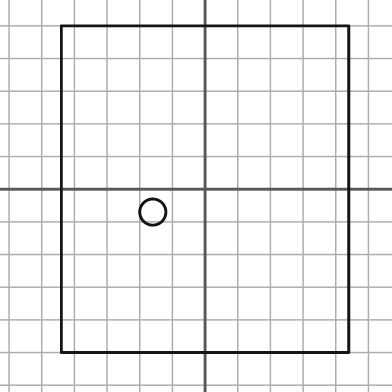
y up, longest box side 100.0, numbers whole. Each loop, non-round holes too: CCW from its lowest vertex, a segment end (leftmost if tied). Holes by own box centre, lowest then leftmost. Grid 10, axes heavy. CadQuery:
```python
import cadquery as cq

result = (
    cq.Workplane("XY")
    .moveTo(-44.0, -50.0)
    .lineTo(44.0, -50.0)
    .lineTo(44.0, 50.0)
    .lineTo(-44.0, 50.0)
    .close()
    .moveTo(-16.0, -7.0)
    .circle(4.0)
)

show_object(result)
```